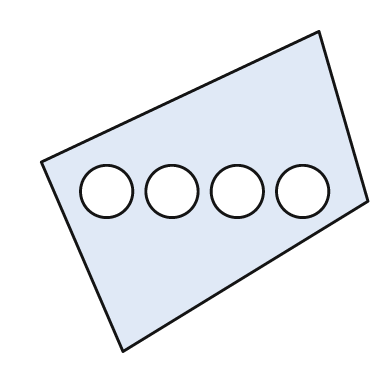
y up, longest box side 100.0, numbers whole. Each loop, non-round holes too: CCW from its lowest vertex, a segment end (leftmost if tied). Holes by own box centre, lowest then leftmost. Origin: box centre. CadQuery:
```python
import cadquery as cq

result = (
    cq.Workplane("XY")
    .moveTo(-25.0, -49.0)
    .lineTo(50.0, -3.0)
    .lineTo(35.0, 49.0)
    .lineTo(-50.0, 9.0)
    .close()
    .moveTo(-30.0, 0.0)
    .circle(8.0)
    .moveTo(-10.0, 0.0)
    .circle(8.0)
    .moveTo(10.0, 0.0)
    .circle(8.0)
    .moveTo(30.0, 0.0)
    .circle(8.0)
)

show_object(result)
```